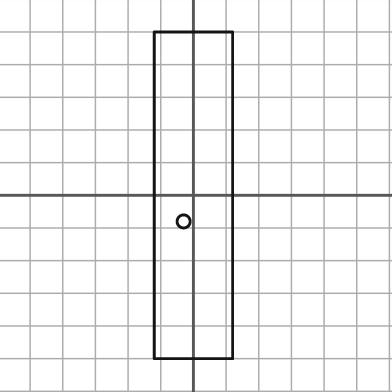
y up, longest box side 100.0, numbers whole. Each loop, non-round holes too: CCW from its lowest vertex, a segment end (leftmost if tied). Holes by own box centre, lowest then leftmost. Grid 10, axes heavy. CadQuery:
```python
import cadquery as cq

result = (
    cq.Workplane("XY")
    .moveTo(-12.0, -50.0)
    .lineTo(12.0, -50.0)
    .lineTo(12.0, 50.0)
    .lineTo(-12.0, 50.0)
    .close()
    .moveTo(-3.0, -8.0)
    .circle(2.0)
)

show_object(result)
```